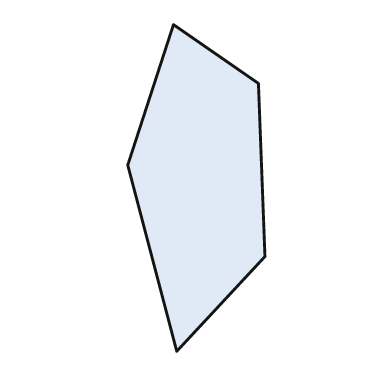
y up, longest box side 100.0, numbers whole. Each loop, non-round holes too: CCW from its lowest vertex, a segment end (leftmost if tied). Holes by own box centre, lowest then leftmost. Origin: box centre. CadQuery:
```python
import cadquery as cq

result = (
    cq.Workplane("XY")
    .moveTo(-6.0, -50.0)
    .lineTo(21.0, -21.0)
    .lineTo(19.0, 32.0)
    .lineTo(-7.0, 50.0)
    .lineTo(-21.0, 7.0)
    .close()
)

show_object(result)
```